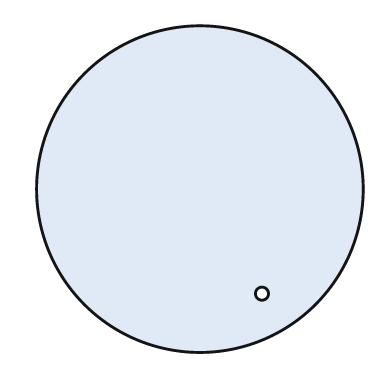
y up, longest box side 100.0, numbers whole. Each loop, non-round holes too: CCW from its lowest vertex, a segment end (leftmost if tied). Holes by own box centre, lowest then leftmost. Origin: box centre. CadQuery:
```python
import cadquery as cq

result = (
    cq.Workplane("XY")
    .moveTo(0.0, 0.0)
    .circle(50.0)
    .moveTo(19.0, -32.0)
    .circle(2.0)
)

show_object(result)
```